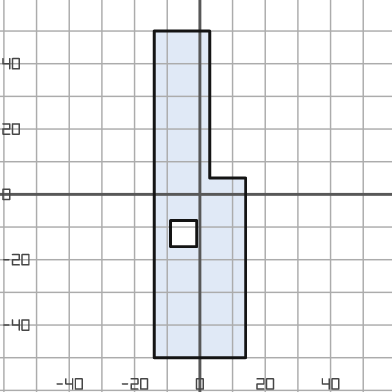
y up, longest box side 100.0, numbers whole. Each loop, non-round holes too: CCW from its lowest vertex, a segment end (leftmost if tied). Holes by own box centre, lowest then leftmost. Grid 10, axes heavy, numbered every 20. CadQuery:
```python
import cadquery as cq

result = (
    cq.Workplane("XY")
    .moveTo(-14.0, -50.0)
    .lineTo(14.0, -50.0)
    .lineTo(14.0, 5.0)
    .lineTo(3.0, 5.0)
    .lineTo(3.0, 50.0)
    .lineTo(-14.0, 50.0)
    .close()
    .moveTo(-9.0, -16.0)
    .lineTo(-1.0, -16.0)
    .lineTo(-1.0, -8.0)
    .lineTo(-9.0, -8.0)
    .close()
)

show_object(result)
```